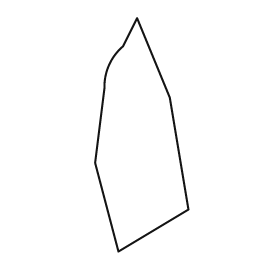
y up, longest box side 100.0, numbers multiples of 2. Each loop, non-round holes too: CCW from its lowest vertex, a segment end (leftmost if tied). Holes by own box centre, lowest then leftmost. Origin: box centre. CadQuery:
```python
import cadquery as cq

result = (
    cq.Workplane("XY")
    .moveTo(-10.0, -50.0)
    .lineTo(20.0, -32.0)
    .lineTo(12.0, 16.0)
    .lineTo(-2.0, 50.0)
    .lineTo(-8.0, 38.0)
    .threePointArc((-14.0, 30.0), (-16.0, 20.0))
    .lineTo(-20.0, -12.0)
    .close()
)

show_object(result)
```